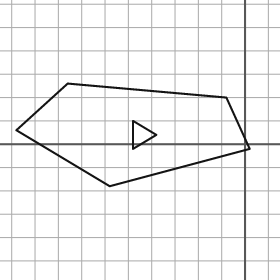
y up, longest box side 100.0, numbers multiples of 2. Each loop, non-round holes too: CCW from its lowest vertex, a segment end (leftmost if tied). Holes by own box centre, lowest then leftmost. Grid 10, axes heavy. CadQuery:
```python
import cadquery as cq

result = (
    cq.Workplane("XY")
    .moveTo(-58.0, -18.0)
    .lineTo(2.0, -2.0)
    .lineTo(-8.0, 20.0)
    .lineTo(-76.0, 26.0)
    .lineTo(-98.0, 6.0)
    .close()
    .moveTo(-48.0, -2.0)
    .lineTo(-38.0, 4.0)
    .lineTo(-48.0, 10.0)
    .close()
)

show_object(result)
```